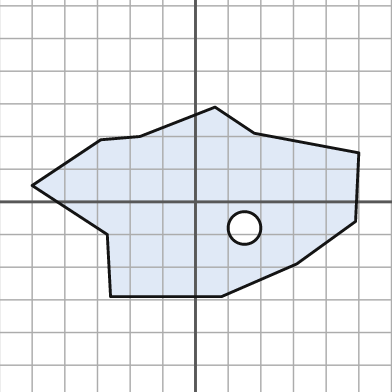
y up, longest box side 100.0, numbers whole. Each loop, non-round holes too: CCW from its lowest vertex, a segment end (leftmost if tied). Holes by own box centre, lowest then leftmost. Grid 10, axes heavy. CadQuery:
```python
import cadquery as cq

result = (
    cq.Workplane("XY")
    .moveTo(-26.0, -29.0)
    .lineTo(8.0, -29.0)
    .lineTo(31.0, -19.0)
    .lineTo(49.0, -6.0)
    .lineTo(50.0, 15.0)
    .lineTo(18.0, 21.0)
    .lineTo(6.0, 29.0)
    .lineTo(-17.0, 20.0)
    .lineTo(-29.0, 19.0)
    .lineTo(-50.0, 5.0)
    .lineTo(-27.0, -10.0)
    .close()
    .moveTo(15.0, -8.0)
    .circle(5.0)
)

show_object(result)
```